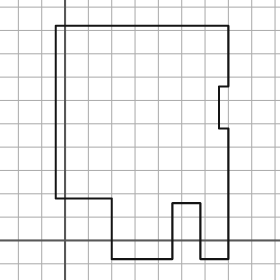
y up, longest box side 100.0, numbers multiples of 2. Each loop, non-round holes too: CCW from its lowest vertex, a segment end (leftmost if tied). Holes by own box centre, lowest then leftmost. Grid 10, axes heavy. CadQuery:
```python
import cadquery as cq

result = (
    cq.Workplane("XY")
    .moveTo(20.0, -8.0)
    .lineTo(46.0, -8.0)
    .lineTo(46.0, 16.0)
    .lineTo(58.0, 16.0)
    .lineTo(58.0, -8.0)
    .lineTo(70.0, -8.0)
    .lineTo(70.0, 48.0)
    .lineTo(66.0, 48.0)
    .lineTo(66.0, 66.0)
    .lineTo(70.0, 66.0)
    .lineTo(70.0, 92.0)
    .lineTo(-4.0, 92.0)
    .lineTo(-4.0, 18.0)
    .lineTo(20.0, 18.0)
    .close()
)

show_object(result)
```